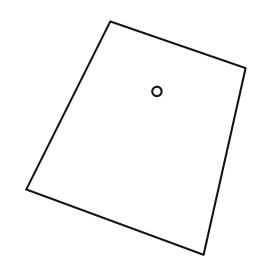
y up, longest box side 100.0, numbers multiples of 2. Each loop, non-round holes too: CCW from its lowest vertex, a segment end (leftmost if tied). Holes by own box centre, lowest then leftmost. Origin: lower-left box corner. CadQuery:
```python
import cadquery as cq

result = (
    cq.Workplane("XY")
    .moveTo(76.0, 0.0)
    .lineTo(94.0, 80.0)
    .lineTo(36.0, 100.0)
    .lineTo(0.0, 28.0)
    .close()
    .moveTo(56.0, 70.0)
    .circle(2.0)
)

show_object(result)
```